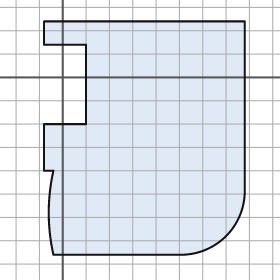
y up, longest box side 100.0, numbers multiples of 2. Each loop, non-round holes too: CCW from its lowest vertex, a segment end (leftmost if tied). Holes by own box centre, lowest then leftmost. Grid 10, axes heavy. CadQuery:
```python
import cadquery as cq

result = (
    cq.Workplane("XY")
    .moveTo(-4.0, -76.0)
    .lineTo(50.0, -76.0)
    .threePointArc((70.0, -68.0), (78.0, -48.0))
    .lineTo(78.0, 24.0)
    .lineTo(-8.0, 24.0)
    .lineTo(-8.0, 14.0)
    .lineTo(10.0, 14.0)
    .lineTo(10.0, -20.0)
    .lineTo(-8.0, -20.0)
    .lineTo(-8.0, -40.0)
    .lineTo(-4.0, -40.0)
    .threePointArc((-6.0, -58.0), (-4.0, -76.0))
    .close()
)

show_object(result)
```